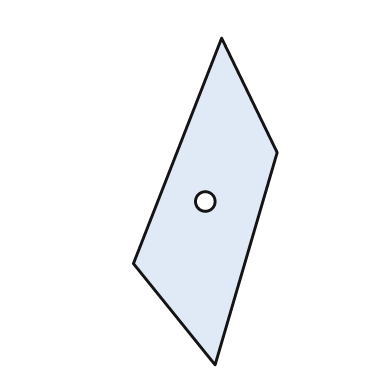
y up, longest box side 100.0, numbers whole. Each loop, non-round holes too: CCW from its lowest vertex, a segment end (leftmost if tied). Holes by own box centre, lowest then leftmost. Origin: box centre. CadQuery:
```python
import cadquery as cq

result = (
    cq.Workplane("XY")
    .moveTo(3.0, -50.0)
    .lineTo(22.0, 15.0)
    .lineTo(5.0, 50.0)
    .lineTo(-22.0, -19.0)
    .close()
    .moveTo(0.0, 0.0)
    .circle(3.0)
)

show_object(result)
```